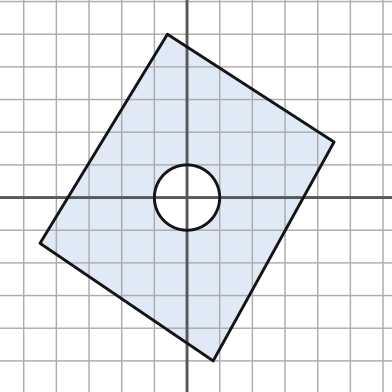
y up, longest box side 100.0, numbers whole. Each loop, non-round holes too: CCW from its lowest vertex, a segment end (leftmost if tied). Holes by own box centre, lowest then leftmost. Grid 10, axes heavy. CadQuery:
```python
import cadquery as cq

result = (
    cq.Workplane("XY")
    .moveTo(8.0, -50.0)
    .lineTo(45.0, 17.0)
    .lineTo(-6.0, 50.0)
    .lineTo(-45.0, -14.0)
    .close()
    .moveTo(0.0, 0.0)
    .circle(10.0)
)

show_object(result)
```